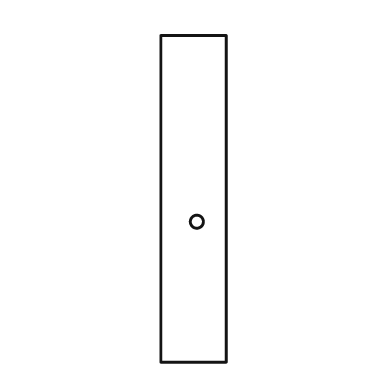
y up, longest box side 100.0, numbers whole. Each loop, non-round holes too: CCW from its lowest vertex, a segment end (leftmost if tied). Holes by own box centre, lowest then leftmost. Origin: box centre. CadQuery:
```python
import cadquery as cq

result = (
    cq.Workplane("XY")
    .moveTo(-10.0, -50.0)
    .lineTo(10.0, -50.0)
    .lineTo(10.0, 50.0)
    .lineTo(-10.0, 50.0)
    .close()
    .moveTo(1.0, -7.0)
    .circle(2.0)
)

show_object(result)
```